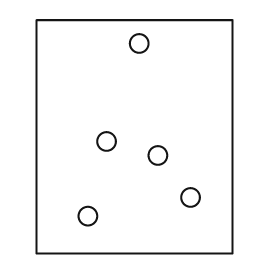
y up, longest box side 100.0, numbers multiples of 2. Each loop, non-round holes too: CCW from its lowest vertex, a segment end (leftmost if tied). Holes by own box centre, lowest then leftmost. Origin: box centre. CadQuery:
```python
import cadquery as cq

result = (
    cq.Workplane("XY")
    .moveTo(-42.0, -50.0)
    .lineTo(42.0, -50.0)
    .lineTo(42.0, 50.0)
    .lineTo(-42.0, 50.0)
    .close()
    .moveTo(-20.0, -34.0)
    .circle(4.0)
    .moveTo(24.0, -26.0)
    .circle(4.0)
    .moveTo(10.0, -8.0)
    .circle(4.0)
    .moveTo(-12.0, -2.0)
    .circle(4.0)
    .moveTo(2.0, 40.0)
    .circle(4.0)
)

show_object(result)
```